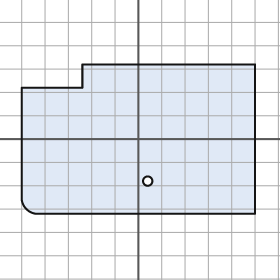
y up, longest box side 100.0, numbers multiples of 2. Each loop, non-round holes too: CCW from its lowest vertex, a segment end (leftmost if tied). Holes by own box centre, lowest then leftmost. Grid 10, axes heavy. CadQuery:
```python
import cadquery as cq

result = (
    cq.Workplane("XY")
    .moveTo(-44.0, -32.0)
    .lineTo(50.0, -32.0)
    .lineTo(50.0, 32.0)
    .lineTo(-24.0, 32.0)
    .lineTo(-24.0, 22.0)
    .lineTo(-50.0, 22.0)
    .lineTo(-50.0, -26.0)
    .threePointArc((-48.0, -30.0), (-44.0, -32.0))
    .close()
    .moveTo(4.0, -18.0)
    .circle(2.0)
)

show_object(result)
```